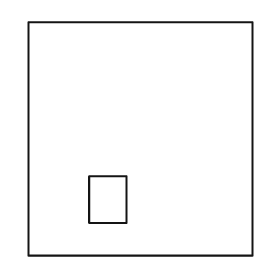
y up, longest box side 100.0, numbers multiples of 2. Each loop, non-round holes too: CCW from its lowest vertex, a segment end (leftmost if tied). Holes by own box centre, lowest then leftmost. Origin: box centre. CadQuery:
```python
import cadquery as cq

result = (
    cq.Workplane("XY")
    .moveTo(-48.0, -50.0)
    .lineTo(48.0, -50.0)
    .lineTo(48.0, 50.0)
    .lineTo(-48.0, 50.0)
    .close()
    .moveTo(-22.0, -36.0)
    .lineTo(-6.0, -36.0)
    .lineTo(-6.0, -16.0)
    .lineTo(-22.0, -16.0)
    .close()
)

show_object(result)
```